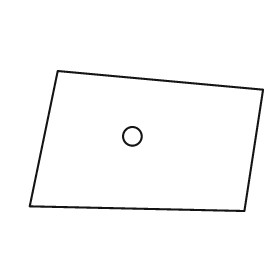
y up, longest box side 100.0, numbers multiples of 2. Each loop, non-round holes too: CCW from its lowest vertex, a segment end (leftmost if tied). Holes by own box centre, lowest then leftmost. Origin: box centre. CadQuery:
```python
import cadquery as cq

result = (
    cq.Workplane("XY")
    .moveTo(42.0, -30.0)
    .lineTo(50.0, 22.0)
    .lineTo(-38.0, 30.0)
    .lineTo(-50.0, -28.0)
    .close()
    .moveTo(-6.0, 2.0)
    .circle(4.0)
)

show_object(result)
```